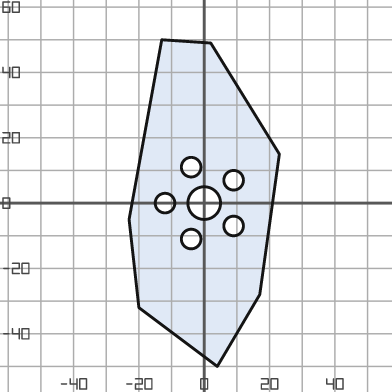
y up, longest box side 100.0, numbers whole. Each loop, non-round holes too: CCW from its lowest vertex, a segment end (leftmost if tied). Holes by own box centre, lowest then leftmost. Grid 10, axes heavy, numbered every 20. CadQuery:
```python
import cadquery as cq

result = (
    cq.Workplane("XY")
    .moveTo(4.0, -50.0)
    .lineTo(17.0, -28.0)
    .lineTo(23.0, 15.0)
    .lineTo(2.0, 49.0)
    .lineTo(-13.0, 50.0)
    .lineTo(-23.0, -5.0)
    .lineTo(-20.0, -32.0)
    .close()
    .moveTo(-4.0, -11.0)
    .circle(3.0)
    .moveTo(9.0, -7.0)
    .circle(3.0)
    .moveTo(-12.0, 0.0)
    .circle(3.0)
    .moveTo(0.0, 0.0)
    .circle(5.0)
    .moveTo(9.0, 7.0)
    .circle(3.0)
    .moveTo(-4.0, 11.0)
    .circle(3.0)
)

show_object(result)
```